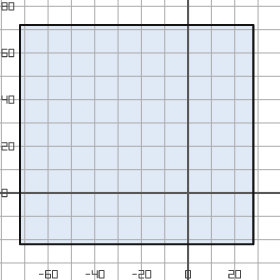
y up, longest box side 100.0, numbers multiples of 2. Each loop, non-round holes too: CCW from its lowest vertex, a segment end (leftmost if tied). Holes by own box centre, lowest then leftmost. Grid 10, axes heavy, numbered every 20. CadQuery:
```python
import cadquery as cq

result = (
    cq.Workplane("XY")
    .moveTo(-72.0, -22.0)
    .lineTo(28.0, -22.0)
    .lineTo(28.0, 72.0)
    .lineTo(-72.0, 72.0)
    .close()
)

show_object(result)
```